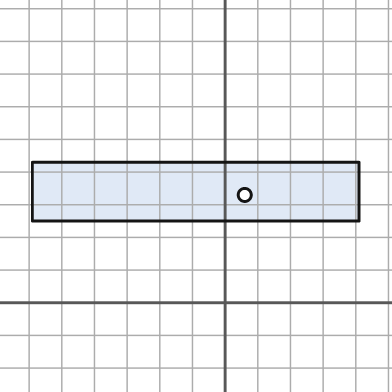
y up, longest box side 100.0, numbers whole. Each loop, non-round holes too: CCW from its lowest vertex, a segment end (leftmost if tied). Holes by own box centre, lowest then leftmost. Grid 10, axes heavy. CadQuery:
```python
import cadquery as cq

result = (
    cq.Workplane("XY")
    .moveTo(-59.0, 25.0)
    .lineTo(41.0, 25.0)
    .lineTo(41.0, 43.0)
    .lineTo(-59.0, 43.0)
    .close()
    .moveTo(6.0, 33.0)
    .circle(2.0)
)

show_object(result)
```